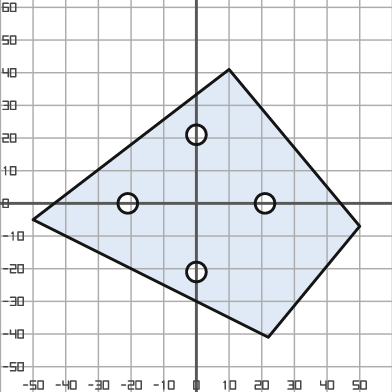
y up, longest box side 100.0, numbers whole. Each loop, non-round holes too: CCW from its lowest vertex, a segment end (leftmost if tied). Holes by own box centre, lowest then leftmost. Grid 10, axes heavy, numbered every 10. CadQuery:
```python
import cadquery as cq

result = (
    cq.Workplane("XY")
    .moveTo(22.0, -41.0)
    .lineTo(50.0, -7.0)
    .lineTo(10.0, 41.0)
    .lineTo(-50.0, -5.0)
    .close()
    .moveTo(0.0, -21.0)
    .circle(3.0)
    .moveTo(-21.0, 0.0)
    .circle(3.0)
    .moveTo(21.0, 0.0)
    .circle(3.0)
    .moveTo(0.0, 21.0)
    .circle(3.0)
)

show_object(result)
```